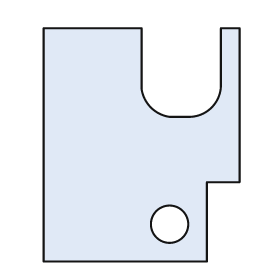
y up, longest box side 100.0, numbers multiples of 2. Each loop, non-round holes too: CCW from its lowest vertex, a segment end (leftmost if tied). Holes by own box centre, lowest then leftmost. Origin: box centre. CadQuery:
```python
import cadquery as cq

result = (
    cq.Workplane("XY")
    .moveTo(-42.0, -50.0)
    .lineTo(28.0, -50.0)
    .lineTo(28.0, -16.0)
    .lineTo(42.0, -16.0)
    .lineTo(42.0, 50.0)
    .lineTo(34.0, 50.0)
    .lineTo(34.0, 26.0)
    .threePointArc((30.0, 16.0), (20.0, 12.0))
    .lineTo(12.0, 12.0)
    .threePointArc((4.0, 16.0), (0.0, 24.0))
    .lineTo(0.0, 50.0)
    .lineTo(-42.0, 50.0)
    .close()
    .moveTo(12.0, -34.0)
    .circle(8.0)
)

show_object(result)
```